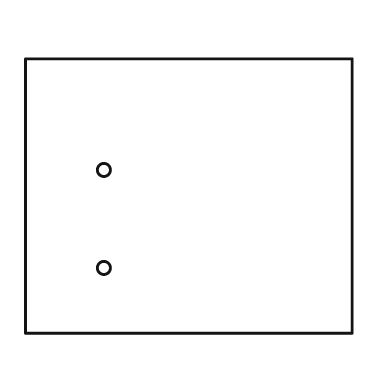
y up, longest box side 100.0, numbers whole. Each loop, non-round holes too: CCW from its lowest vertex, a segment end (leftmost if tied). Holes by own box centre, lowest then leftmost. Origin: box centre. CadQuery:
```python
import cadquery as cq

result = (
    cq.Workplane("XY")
    .moveTo(-50.0, -42.0)
    .lineTo(50.0, -42.0)
    .lineTo(50.0, 42.0)
    .lineTo(-50.0, 42.0)
    .close()
    .moveTo(-26.0, -22.0)
    .circle(2.0)
    .moveTo(-26.0, 8.0)
    .circle(2.0)
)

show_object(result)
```